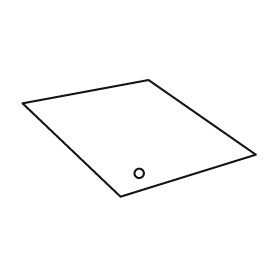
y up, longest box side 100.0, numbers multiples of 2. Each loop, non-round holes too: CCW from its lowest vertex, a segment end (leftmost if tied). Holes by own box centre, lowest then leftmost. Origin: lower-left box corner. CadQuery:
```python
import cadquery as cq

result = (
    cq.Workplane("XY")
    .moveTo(42.0, 0.0)
    .lineTo(100.0, 18.0)
    .lineTo(54.0, 50.0)
    .lineTo(0.0, 40.0)
    .close()
    .moveTo(50.0, 10.0)
    .circle(2.0)
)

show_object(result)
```